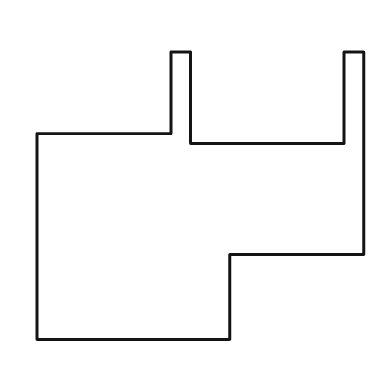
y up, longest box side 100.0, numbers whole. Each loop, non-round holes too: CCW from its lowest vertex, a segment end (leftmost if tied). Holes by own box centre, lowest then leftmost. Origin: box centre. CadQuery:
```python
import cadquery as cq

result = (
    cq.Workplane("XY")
    .moveTo(-50.0, -44.0)
    .lineTo(9.0, -44.0)
    .lineTo(9.0, -18.0)
    .lineTo(50.0, -18.0)
    .lineTo(50.0, 44.0)
    .lineTo(44.0, 44.0)
    .lineTo(44.0, 16.0)
    .lineTo(-3.0, 16.0)
    .lineTo(-3.0, 44.0)
    .lineTo(-9.0, 44.0)
    .lineTo(-9.0, 19.0)
    .lineTo(-50.0, 19.0)
    .close()
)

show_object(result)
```